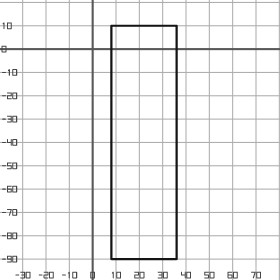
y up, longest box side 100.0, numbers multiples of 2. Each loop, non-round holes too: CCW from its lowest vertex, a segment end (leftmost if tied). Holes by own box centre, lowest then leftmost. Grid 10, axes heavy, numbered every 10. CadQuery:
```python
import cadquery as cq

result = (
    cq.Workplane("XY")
    .moveTo(8.0, -90.0)
    .lineTo(36.0, -90.0)
    .lineTo(36.0, 10.0)
    .lineTo(8.0, 10.0)
    .close()
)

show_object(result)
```